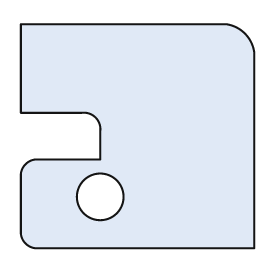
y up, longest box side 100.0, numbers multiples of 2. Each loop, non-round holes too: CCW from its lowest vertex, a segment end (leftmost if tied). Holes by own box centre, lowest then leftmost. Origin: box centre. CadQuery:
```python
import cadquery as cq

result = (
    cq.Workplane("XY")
    .moveTo(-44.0, -48.0)
    .lineTo(50.0, -48.0)
    .lineTo(50.0, 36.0)
    .threePointArc((46.0, 44.0), (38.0, 48.0))
    .lineTo(-50.0, 48.0)
    .lineTo(-50.0, 10.0)
    .lineTo(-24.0, 10.0)
    .threePointArc((-18.0, 8.0), (-16.0, 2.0))
    .lineTo(-16.0, -10.0)
    .lineTo(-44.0, -10.0)
    .threePointArc((-48.0, -12.0), (-50.0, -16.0))
    .lineTo(-50.0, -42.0)
    .threePointArc((-48.0, -46.0), (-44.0, -48.0))
    .close()
    .moveTo(-16.0, -26.0)
    .circle(10.0)
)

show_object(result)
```